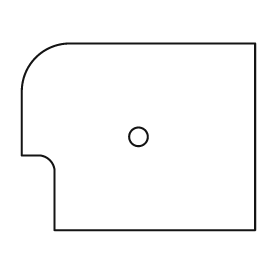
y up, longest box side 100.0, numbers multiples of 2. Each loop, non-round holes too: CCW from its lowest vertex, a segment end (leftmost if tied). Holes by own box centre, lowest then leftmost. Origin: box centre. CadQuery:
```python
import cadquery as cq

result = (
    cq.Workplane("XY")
    .moveTo(-36.0, -40.0)
    .lineTo(50.0, -40.0)
    .lineTo(50.0, 40.0)
    .lineTo(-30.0, 40.0)
    .threePointArc((-44.0, 34.0), (-50.0, 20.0))
    .lineTo(-50.0, -8.0)
    .lineTo(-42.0, -8.0)
    .threePointArc((-38.0, -10.0), (-36.0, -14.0))
    .close()
    .moveTo(0.0, 0.0)
    .circle(4.0)
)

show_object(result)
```